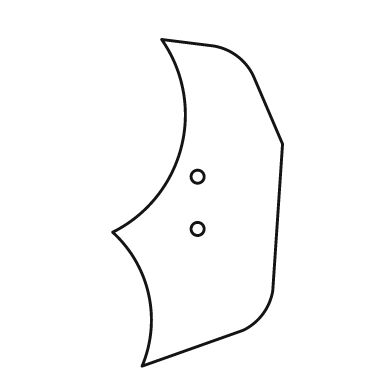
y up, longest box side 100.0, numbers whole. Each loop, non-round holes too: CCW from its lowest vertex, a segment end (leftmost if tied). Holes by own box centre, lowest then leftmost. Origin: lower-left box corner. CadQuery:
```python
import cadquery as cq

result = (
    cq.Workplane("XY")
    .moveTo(9.0, 0.0)
    .lineTo(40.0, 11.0)
    .threePointArc((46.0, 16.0), (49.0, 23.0))
    .lineTo(52.0, 68.0)
    .lineTo(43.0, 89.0)
    .threePointArc((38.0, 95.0), (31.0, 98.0))
    .lineTo(15.0, 100.0)
    .threePointArc((21.0, 67.0), (0.0, 41.0))
    .threePointArc((11.0, 22.0), (9.0, 0.0))
    .close()
    .moveTo(26.0, 42.0)
    .circle(2.0)
    .moveTo(26.0, 58.0)
    .circle(2.0)
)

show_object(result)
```